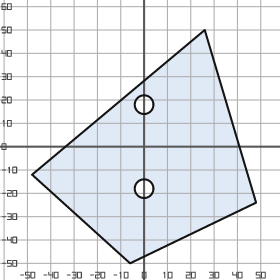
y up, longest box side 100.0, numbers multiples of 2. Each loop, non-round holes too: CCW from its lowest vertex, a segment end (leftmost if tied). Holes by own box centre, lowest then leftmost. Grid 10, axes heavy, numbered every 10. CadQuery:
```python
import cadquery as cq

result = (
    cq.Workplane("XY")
    .moveTo(-6.0, -50.0)
    .lineTo(48.0, -24.0)
    .lineTo(26.0, 50.0)
    .lineTo(-48.0, -12.0)
    .close()
    .moveTo(0.0, -18.0)
    .circle(4.0)
    .moveTo(0.0, 18.0)
    .circle(4.0)
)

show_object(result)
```